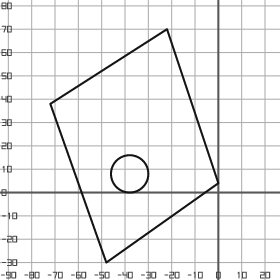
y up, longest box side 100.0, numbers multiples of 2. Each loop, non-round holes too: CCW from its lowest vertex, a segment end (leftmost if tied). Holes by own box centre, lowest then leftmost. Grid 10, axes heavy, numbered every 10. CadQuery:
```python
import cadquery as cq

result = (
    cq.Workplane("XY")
    .moveTo(-48.0, -30.0)
    .lineTo(0.0, 4.0)
    .lineTo(-22.0, 70.0)
    .lineTo(-72.0, 38.0)
    .close()
    .moveTo(-38.0, 8.0)
    .circle(8.0)
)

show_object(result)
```